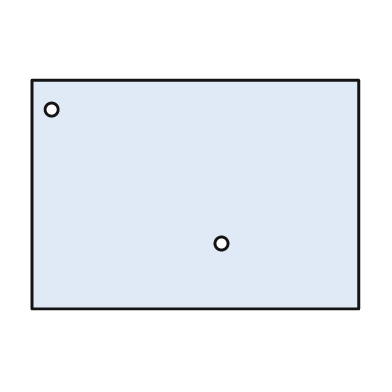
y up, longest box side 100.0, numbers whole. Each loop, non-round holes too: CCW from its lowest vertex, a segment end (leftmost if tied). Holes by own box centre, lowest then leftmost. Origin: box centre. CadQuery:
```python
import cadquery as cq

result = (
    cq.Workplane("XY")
    .moveTo(-50.0, -35.0)
    .lineTo(50.0, -35.0)
    .lineTo(50.0, 35.0)
    .lineTo(-50.0, 35.0)
    .close()
    .moveTo(8.0, -15.0)
    .circle(2.0)
    .moveTo(-44.0, 26.0)
    .circle(2.0)
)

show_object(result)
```